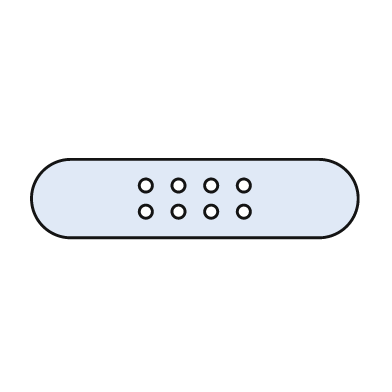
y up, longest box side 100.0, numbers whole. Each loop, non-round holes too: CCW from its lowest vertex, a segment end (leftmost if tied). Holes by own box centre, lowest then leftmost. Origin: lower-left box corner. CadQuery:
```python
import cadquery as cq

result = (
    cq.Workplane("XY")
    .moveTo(12.0, 0.0)
    .lineTo(88.0, 0.0)
    .threePointArc((100.0, 12.0), (88.0, 24.0))
    .lineTo(12.0, 24.0)
    .threePointArc((0.0, 12.0), (12.0, 0.0))
    .close()
    .moveTo(35.0, 8.0)
    .circle(2.0)
    .moveTo(45.0, 8.0)
    .circle(2.0)
    .moveTo(55.0, 8.0)
    .circle(2.0)
    .moveTo(65.0, 8.0)
    .circle(2.0)
    .moveTo(35.0, 16.0)
    .circle(2.0)
    .moveTo(45.0, 16.0)
    .circle(2.0)
    .moveTo(55.0, 16.0)
    .circle(2.0)
    .moveTo(65.0, 16.0)
    .circle(2.0)
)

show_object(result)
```